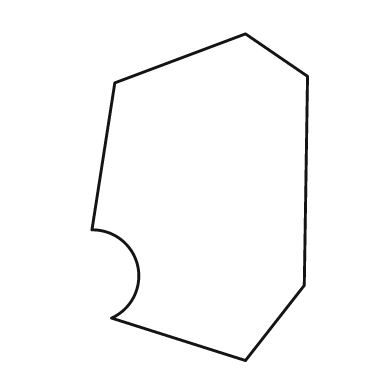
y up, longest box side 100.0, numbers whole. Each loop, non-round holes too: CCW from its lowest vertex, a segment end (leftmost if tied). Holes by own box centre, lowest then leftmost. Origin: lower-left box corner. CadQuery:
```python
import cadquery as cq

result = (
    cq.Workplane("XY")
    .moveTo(47.0, 0.0)
    .lineTo(65.0, 23.0)
    .lineTo(66.0, 87.0)
    .lineTo(47.0, 100.0)
    .lineTo(7.0, 85.0)
    .lineTo(0.0, 40.0)
    .threePointArc((14.0, 29.0), (6.0, 13.0))
    .close()
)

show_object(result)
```